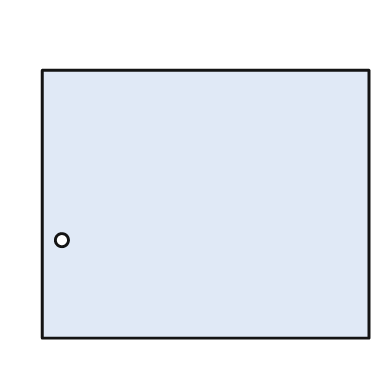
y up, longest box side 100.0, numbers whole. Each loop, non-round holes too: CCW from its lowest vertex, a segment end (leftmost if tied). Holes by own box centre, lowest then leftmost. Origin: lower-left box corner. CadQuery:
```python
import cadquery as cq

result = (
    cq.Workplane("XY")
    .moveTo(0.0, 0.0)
    .lineTo(100.0, 0.0)
    .lineTo(100.0, 82.0)
    .lineTo(0.0, 82.0)
    .close()
    .moveTo(6.0, 30.0)
    .circle(2.0)
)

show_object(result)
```